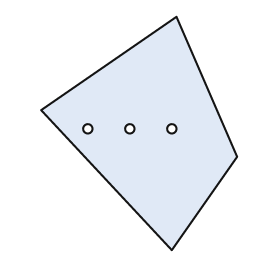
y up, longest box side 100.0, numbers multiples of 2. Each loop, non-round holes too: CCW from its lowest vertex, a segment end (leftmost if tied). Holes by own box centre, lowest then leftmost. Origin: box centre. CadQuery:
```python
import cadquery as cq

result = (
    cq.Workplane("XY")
    .moveTo(14.0, -50.0)
    .lineTo(42.0, -10.0)
    .lineTo(16.0, 50.0)
    .lineTo(-42.0, 10.0)
    .close()
    .moveTo(-22.0, 2.0)
    .circle(2.0)
    .moveTo(-4.0, 2.0)
    .circle(2.0)
    .moveTo(14.0, 2.0)
    .circle(2.0)
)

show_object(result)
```